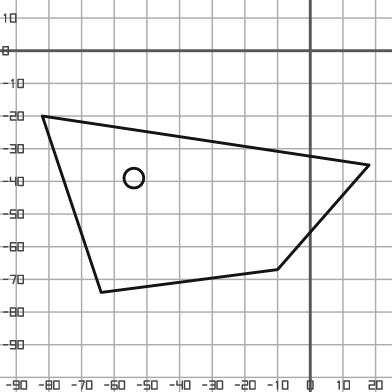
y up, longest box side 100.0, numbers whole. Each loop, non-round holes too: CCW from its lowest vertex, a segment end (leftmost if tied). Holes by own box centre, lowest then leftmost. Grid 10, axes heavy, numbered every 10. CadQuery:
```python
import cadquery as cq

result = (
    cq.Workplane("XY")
    .moveTo(-64.0, -74.0)
    .lineTo(-10.0, -67.0)
    .lineTo(18.0, -35.0)
    .lineTo(-82.0, -20.0)
    .close()
    .moveTo(-54.0, -39.0)
    .circle(3.0)
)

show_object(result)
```